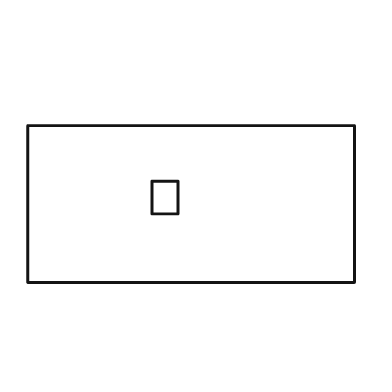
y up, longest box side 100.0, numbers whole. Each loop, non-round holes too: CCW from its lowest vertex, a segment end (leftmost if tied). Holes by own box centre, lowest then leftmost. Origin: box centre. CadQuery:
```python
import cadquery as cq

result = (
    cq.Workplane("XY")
    .moveTo(-50.0, -24.0)
    .lineTo(50.0, -24.0)
    .lineTo(50.0, 24.0)
    .lineTo(-50.0, 24.0)
    .close()
    .moveTo(-12.0, -3.0)
    .lineTo(-4.0, -3.0)
    .lineTo(-4.0, 7.0)
    .lineTo(-12.0, 7.0)
    .close()
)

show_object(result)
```